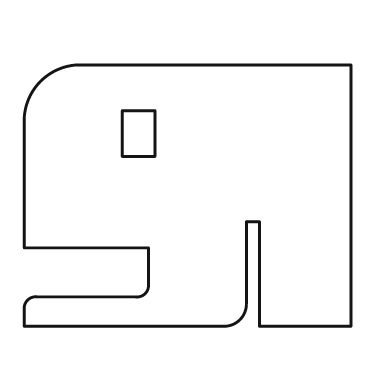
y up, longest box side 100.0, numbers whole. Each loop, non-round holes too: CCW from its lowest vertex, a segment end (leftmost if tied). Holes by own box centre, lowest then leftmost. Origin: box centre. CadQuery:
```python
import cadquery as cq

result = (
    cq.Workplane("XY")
    .moveTo(-50.0, -40.0)
    .lineTo(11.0, -40.0)
    .threePointArc((16.0, -38.0), (18.0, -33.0))
    .lineTo(18.0, -8.0)
    .lineTo(22.0, -8.0)
    .lineTo(22.0, -40.0)
    .lineTo(50.0, -40.0)
    .lineTo(50.0, 40.0)
    .lineTo(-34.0, 40.0)
    .threePointArc((-45.0, 35.0), (-50.0, 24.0))
    .lineTo(-50.0, -16.0)
    .lineTo(-12.0, -16.0)
    .lineTo(-12.0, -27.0)
    .threePointArc((-13.0, -30.0), (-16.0, -31.0))
    .lineTo(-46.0, -31.0)
    .threePointArc((-49.0, -32.0), (-50.0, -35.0))
    .close()
    .moveTo(-20.0, 12.0)
    .lineTo(-10.0, 12.0)
    .lineTo(-10.0, 26.0)
    .lineTo(-20.0, 26.0)
    .close()
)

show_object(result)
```